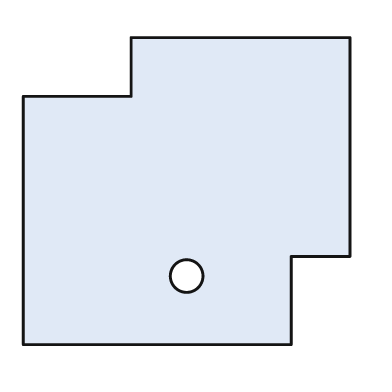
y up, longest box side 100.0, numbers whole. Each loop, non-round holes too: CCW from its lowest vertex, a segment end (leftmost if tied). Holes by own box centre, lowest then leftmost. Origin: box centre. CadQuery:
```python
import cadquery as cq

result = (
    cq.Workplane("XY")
    .moveTo(-50.0, -47.0)
    .lineTo(32.0, -47.0)
    .lineTo(32.0, -20.0)
    .lineTo(50.0, -20.0)
    .lineTo(50.0, 47.0)
    .lineTo(-17.0, 47.0)
    .lineTo(-17.0, 29.0)
    .lineTo(-50.0, 29.0)
    .close()
    .moveTo(0.0, -26.0)
    .circle(5.0)
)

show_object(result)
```